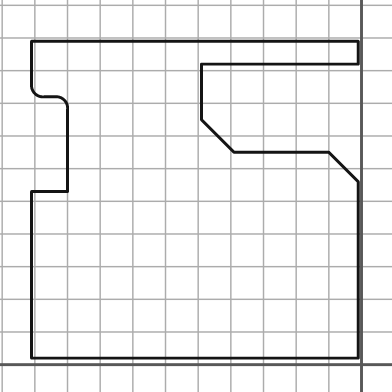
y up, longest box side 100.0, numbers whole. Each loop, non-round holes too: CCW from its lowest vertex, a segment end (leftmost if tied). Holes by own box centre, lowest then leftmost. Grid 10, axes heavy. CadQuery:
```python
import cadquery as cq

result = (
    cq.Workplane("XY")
    .moveTo(-101.0, 2.0)
    .lineTo(-1.0, 2.0)
    .lineTo(-1.0, 56.0)
    .lineTo(-10.0, 65.0)
    .lineTo(-39.0, 65.0)
    .lineTo(-49.0, 75.0)
    .lineTo(-49.0, 92.0)
    .lineTo(-1.0, 92.0)
    .lineTo(-1.0, 99.0)
    .lineTo(-101.0, 99.0)
    .lineTo(-101.0, 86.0)
    .threePointArc((-100.0, 83.0), (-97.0, 82.0))
    .lineTo(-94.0, 82.0)
    .threePointArc((-91.0, 81.0), (-90.0, 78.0))
    .lineTo(-90.0, 53.0)
    .lineTo(-101.0, 53.0)
    .close()
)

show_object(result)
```